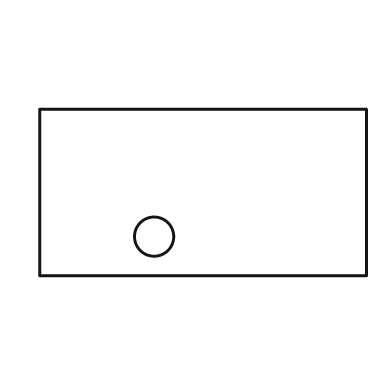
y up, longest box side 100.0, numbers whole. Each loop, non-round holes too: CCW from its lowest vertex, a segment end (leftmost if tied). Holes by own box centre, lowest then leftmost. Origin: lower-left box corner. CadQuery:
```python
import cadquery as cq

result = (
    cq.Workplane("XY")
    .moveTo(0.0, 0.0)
    .lineTo(100.0, 0.0)
    .lineTo(100.0, 51.0)
    .lineTo(0.0, 51.0)
    .close()
    .moveTo(35.0, 12.0)
    .circle(6.0)
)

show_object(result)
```